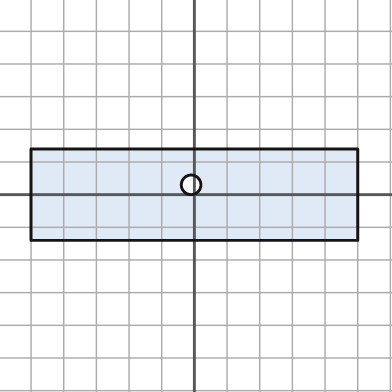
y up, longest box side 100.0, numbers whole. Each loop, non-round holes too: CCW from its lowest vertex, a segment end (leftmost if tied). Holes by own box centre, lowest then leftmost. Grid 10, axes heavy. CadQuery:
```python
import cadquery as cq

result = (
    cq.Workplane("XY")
    .moveTo(-50.0, -14.0)
    .lineTo(50.0, -14.0)
    .lineTo(50.0, 14.0)
    .lineTo(-50.0, 14.0)
    .close()
    .moveTo(-1.0, 3.0)
    .circle(3.0)
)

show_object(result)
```